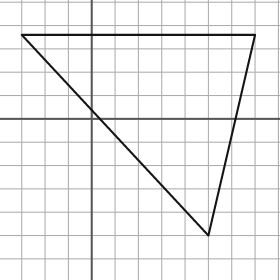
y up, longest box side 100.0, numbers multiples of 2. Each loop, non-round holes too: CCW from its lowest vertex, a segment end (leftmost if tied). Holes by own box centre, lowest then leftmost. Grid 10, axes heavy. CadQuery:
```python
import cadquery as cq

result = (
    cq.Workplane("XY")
    .moveTo(50.0, -50.0)
    .lineTo(70.0, 36.0)
    .lineTo(-30.0, 36.0)
    .close()
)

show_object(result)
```